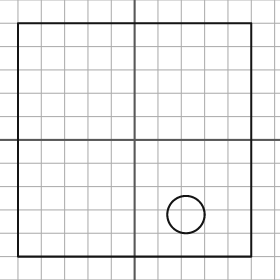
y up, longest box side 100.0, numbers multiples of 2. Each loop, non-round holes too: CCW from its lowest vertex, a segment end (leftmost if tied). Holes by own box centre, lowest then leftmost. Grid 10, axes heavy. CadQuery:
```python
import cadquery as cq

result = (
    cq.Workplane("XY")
    .moveTo(-50.0, -50.0)
    .lineTo(50.0, -50.0)
    .lineTo(50.0, 50.0)
    .lineTo(-50.0, 50.0)
    .close()
    .moveTo(22.0, -32.0)
    .circle(8.0)
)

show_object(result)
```